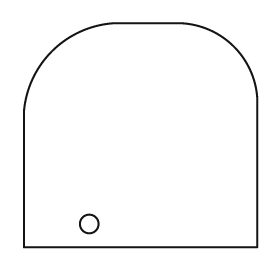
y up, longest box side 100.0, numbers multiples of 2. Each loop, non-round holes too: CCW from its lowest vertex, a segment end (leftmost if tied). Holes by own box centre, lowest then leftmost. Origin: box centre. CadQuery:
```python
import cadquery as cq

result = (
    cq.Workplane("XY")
    .moveTo(-50.0, -48.0)
    .lineTo(50.0, -48.0)
    .lineTo(50.0, 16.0)
    .threePointArc((40.0, 38.0), (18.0, 48.0))
    .lineTo(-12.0, 48.0)
    .threePointArc((-38.0, 36.0), (-50.0, 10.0))
    .close()
    .moveTo(-22.0, -38.0)
    .circle(4.0)
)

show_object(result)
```